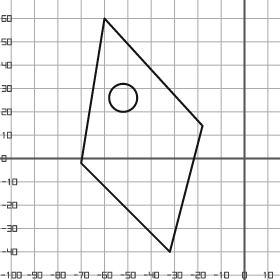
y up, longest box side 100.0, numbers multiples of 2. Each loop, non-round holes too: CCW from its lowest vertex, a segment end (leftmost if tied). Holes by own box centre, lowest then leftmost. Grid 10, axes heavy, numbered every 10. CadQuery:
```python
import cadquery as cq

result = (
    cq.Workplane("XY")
    .moveTo(-32.0, -40.0)
    .lineTo(-18.0, 14.0)
    .lineTo(-60.0, 60.0)
    .lineTo(-70.0, -2.0)
    .close()
    .moveTo(-52.0, 26.0)
    .circle(6.0)
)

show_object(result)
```